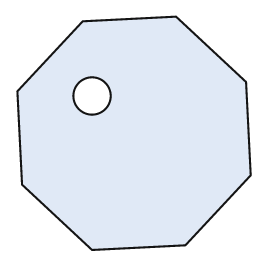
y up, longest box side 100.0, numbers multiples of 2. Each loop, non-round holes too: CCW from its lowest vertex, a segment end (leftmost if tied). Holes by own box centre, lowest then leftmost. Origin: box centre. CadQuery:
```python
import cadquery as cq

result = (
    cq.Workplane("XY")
    .moveTo(-18.0, -50.0)
    .lineTo(22.0, -48.0)
    .lineTo(50.0, -18.0)
    .lineTo(48.0, 22.0)
    .lineTo(18.0, 50.0)
    .lineTo(-22.0, 48.0)
    .lineTo(-50.0, 18.0)
    .lineTo(-48.0, -22.0)
    .close()
    .moveTo(-18.0, 16.0)
    .circle(8.0)
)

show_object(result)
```